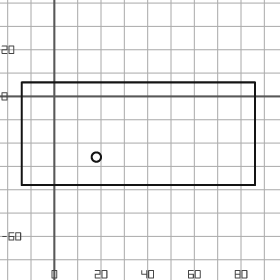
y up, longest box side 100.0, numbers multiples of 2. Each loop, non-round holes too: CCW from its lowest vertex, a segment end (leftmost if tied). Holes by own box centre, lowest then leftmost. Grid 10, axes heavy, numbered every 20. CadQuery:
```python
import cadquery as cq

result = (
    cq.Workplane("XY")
    .moveTo(-14.0, -38.0)
    .lineTo(86.0, -38.0)
    .lineTo(86.0, 6.0)
    .lineTo(-14.0, 6.0)
    .close()
    .moveTo(18.0, -26.0)
    .circle(2.0)
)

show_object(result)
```